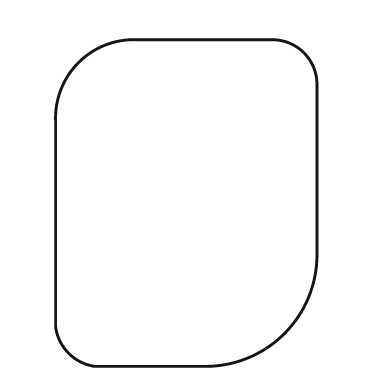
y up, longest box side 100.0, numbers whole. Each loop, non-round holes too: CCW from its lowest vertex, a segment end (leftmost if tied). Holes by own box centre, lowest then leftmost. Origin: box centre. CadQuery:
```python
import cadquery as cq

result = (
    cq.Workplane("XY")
    .moveTo(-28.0, -50.0)
    .lineTo(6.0, -50.0)
    .threePointArc((30.0, -40.0), (40.0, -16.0))
    .lineTo(40.0, 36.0)
    .threePointArc((36.0, 46.0), (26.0, 50.0))
    .lineTo(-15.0, 50.0)
    .threePointArc((-33.0, 43.0), (-40.0, 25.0))
    .lineTo(-40.0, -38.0)
    .threePointArc((-36.0, -46.0), (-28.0, -50.0))
    .close()
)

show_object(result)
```